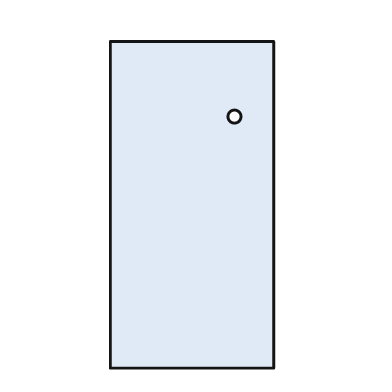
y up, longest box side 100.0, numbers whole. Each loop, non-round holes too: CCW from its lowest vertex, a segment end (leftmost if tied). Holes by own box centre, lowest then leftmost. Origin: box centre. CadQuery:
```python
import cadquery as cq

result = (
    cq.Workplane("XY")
    .moveTo(-25.0, -50.0)
    .lineTo(25.0, -50.0)
    .lineTo(25.0, 50.0)
    .lineTo(-25.0, 50.0)
    .close()
    .moveTo(13.0, 27.0)
    .circle(2.0)
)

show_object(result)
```